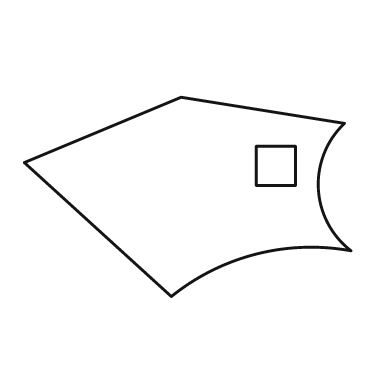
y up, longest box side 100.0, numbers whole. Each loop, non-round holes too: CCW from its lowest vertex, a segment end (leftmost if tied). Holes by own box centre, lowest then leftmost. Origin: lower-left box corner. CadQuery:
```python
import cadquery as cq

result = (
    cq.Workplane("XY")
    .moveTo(45.0, 0.0)
    .threePointArc((71.0, 13.0), (100.0, 14.0))
    .threePointArc((90.0, 33.0), (98.0, 53.0))
    .lineTo(48.0, 61.0)
    .lineTo(0.0, 41.0)
    .close()
    .moveTo(71.0, 34.0)
    .lineTo(83.0, 34.0)
    .lineTo(83.0, 46.0)
    .lineTo(71.0, 46.0)
    .close()
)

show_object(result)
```